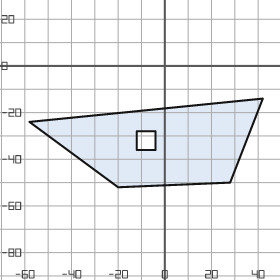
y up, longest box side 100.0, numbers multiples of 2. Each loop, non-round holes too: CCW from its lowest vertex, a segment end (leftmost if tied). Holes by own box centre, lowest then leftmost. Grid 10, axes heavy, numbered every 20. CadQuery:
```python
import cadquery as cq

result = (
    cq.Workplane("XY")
    .moveTo(-20.0, -52.0)
    .lineTo(28.0, -50.0)
    .lineTo(42.0, -14.0)
    .lineTo(-58.0, -24.0)
    .close()
    .moveTo(-12.0, -36.0)
    .lineTo(-4.0, -36.0)
    .lineTo(-4.0, -28.0)
    .lineTo(-12.0, -28.0)
    .close()
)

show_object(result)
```